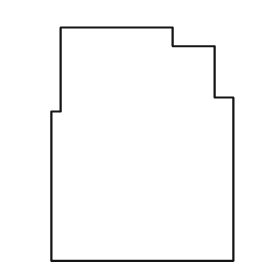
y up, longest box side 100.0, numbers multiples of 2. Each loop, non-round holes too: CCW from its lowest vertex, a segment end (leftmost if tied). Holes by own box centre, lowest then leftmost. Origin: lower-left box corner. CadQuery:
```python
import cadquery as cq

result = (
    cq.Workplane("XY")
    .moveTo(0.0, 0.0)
    .lineTo(78.0, 0.0)
    .lineTo(78.0, 70.0)
    .lineTo(70.0, 70.0)
    .lineTo(70.0, 92.0)
    .lineTo(52.0, 92.0)
    .lineTo(52.0, 100.0)
    .lineTo(4.0, 100.0)
    .lineTo(4.0, 64.0)
    .lineTo(0.0, 64.0)
    .close()
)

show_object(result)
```